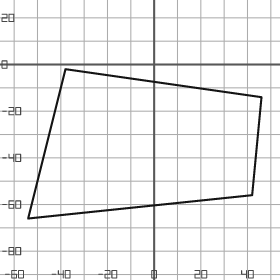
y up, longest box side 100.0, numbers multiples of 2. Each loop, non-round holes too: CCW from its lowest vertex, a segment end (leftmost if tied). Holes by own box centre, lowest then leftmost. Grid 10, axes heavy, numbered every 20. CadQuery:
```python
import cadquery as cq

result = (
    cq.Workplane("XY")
    .moveTo(-54.0, -66.0)
    .lineTo(42.0, -56.0)
    .lineTo(46.0, -14.0)
    .lineTo(-38.0, -2.0)
    .close()
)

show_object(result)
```